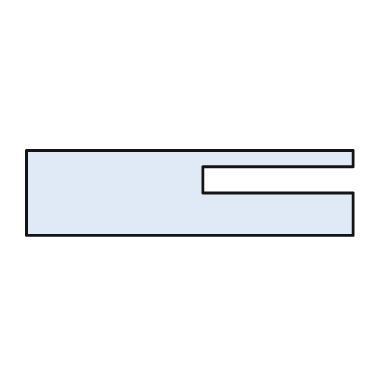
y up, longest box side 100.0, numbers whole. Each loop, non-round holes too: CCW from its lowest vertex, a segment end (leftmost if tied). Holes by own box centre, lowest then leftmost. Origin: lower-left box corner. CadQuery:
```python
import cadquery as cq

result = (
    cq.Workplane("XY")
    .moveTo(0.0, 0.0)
    .lineTo(100.0, 0.0)
    .lineTo(100.0, 13.0)
    .lineTo(54.0, 13.0)
    .lineTo(54.0, 21.0)
    .lineTo(100.0, 21.0)
    .lineTo(100.0, 26.0)
    .lineTo(0.0, 26.0)
    .close()
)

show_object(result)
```